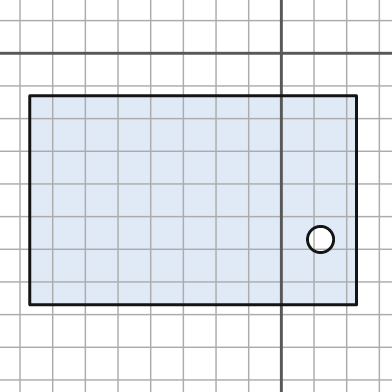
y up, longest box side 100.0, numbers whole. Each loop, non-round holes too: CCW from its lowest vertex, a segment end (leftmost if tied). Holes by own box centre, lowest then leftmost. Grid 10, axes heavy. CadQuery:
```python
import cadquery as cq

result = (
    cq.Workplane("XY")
    .moveTo(-77.0, -77.0)
    .lineTo(23.0, -77.0)
    .lineTo(23.0, -13.0)
    .lineTo(-77.0, -13.0)
    .close()
    .moveTo(12.0, -57.0)
    .circle(4.0)
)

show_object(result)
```